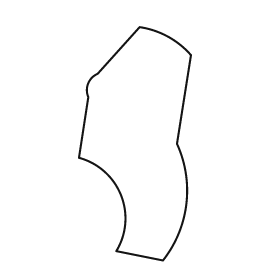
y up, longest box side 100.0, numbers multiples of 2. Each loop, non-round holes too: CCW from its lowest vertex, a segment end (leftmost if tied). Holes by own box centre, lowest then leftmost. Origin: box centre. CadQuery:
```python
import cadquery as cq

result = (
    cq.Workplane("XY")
    .moveTo(12.0, -50.0)
    .threePointArc((22.0, -26.0), (18.0, 0.0))
    .lineTo(24.0, 38.0)
    .threePointArc((14.0, 46.0), (2.0, 50.0))
    .lineTo(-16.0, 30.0)
    .threePointArc((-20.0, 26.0), (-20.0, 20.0))
    .lineTo(-24.0, -6.0)
    .threePointArc((-6.0, -22.0), (-8.0, -46.0))
    .close()
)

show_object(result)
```